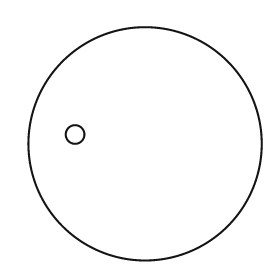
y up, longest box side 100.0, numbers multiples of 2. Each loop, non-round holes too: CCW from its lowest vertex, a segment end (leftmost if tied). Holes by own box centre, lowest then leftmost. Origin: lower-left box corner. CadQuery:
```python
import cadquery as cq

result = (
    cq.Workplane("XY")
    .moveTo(50.0, 50.0)
    .circle(50.0)
    .moveTo(20.0, 54.0)
    .circle(4.0)
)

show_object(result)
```